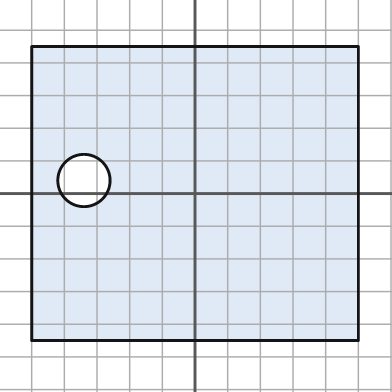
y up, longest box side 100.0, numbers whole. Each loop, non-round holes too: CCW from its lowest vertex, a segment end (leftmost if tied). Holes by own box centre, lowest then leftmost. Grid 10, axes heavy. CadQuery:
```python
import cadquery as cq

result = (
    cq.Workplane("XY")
    .moveTo(-50.0, -45.0)
    .lineTo(50.0, -45.0)
    .lineTo(50.0, 45.0)
    .lineTo(-50.0, 45.0)
    .close()
    .moveTo(-34.0, 4.0)
    .circle(8.0)
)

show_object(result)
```